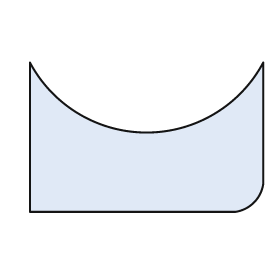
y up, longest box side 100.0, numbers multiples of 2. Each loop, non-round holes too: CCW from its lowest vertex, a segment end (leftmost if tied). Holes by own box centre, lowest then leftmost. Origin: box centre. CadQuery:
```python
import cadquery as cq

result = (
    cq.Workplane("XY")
    .moveTo(-50.0, -32.0)
    .lineTo(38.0, -32.0)
    .threePointArc((46.0, -28.0), (50.0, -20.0))
    .lineTo(50.0, 32.0)
    .threePointArc((0.0, 2.0), (-50.0, 32.0))
    .close()
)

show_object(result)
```